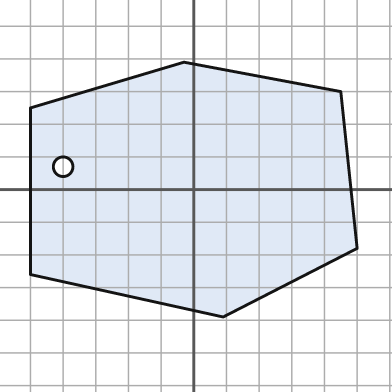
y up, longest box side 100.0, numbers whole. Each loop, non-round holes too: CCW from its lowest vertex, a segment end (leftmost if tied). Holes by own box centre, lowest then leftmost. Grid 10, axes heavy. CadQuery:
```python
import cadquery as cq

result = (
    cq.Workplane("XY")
    .moveTo(9.0, -39.0)
    .lineTo(50.0, -18.0)
    .lineTo(45.0, 30.0)
    .lineTo(-3.0, 39.0)
    .lineTo(-50.0, 25.0)
    .lineTo(-50.0, -26.0)
    .close()
    .moveTo(-40.0, 7.0)
    .circle(3.0)
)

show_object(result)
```